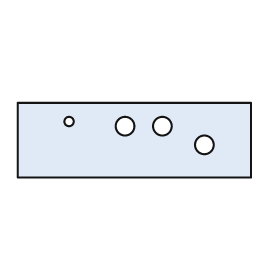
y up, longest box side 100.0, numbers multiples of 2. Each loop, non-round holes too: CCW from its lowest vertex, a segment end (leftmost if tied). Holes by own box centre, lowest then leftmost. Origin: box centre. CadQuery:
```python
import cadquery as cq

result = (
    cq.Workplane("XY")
    .moveTo(-50.0, -16.0)
    .lineTo(50.0, -16.0)
    .lineTo(50.0, 16.0)
    .lineTo(-50.0, 16.0)
    .close()
    .moveTo(30.0, -2.0)
    .circle(4.0)
    .moveTo(-4.0, 6.0)
    .circle(4.0)
    .moveTo(12.0, 6.0)
    .circle(4.0)
    .moveTo(-28.0, 8.0)
    .circle(2.0)
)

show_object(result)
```